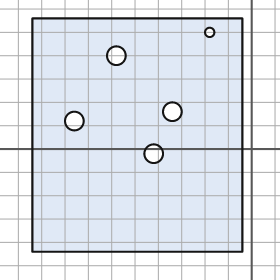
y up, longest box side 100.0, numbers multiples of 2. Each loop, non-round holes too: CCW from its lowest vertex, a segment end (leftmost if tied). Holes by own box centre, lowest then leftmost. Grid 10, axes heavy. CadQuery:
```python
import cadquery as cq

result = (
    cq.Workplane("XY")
    .moveTo(-94.0, -44.0)
    .lineTo(-4.0, -44.0)
    .lineTo(-4.0, 56.0)
    .lineTo(-94.0, 56.0)
    .close()
    .moveTo(-42.0, -2.0)
    .circle(4.0)
    .moveTo(-76.0, 12.0)
    .circle(4.0)
    .moveTo(-34.0, 16.0)
    .circle(4.0)
    .moveTo(-58.0, 40.0)
    .circle(4.0)
    .moveTo(-18.0, 50.0)
    .circle(2.0)
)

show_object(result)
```